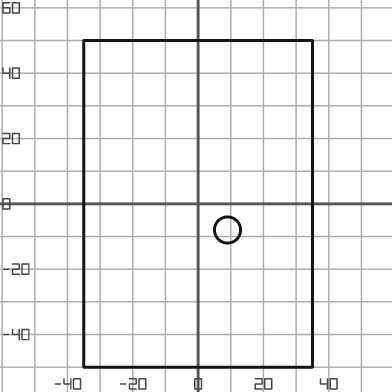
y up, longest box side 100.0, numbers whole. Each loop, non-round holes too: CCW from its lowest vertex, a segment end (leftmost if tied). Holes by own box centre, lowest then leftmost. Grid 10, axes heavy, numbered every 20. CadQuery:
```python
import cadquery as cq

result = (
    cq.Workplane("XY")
    .moveTo(-35.0, -50.0)
    .lineTo(35.0, -50.0)
    .lineTo(35.0, 50.0)
    .lineTo(-35.0, 50.0)
    .close()
    .moveTo(9.0, -8.0)
    .circle(4.0)
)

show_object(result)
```